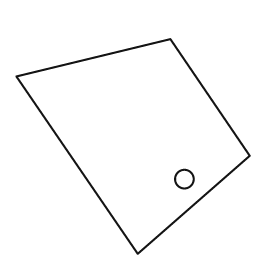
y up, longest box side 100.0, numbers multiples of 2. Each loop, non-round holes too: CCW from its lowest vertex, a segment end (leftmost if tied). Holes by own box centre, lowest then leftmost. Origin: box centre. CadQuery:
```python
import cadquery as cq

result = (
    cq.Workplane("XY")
    .moveTo(2.0, -46.0)
    .lineTo(50.0, -4.0)
    .lineTo(16.0, 46.0)
    .lineTo(-50.0, 30.0)
    .close()
    .moveTo(22.0, -14.0)
    .circle(4.0)
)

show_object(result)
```